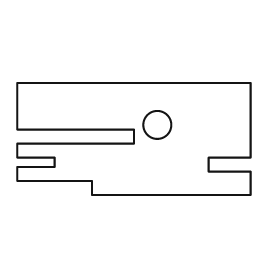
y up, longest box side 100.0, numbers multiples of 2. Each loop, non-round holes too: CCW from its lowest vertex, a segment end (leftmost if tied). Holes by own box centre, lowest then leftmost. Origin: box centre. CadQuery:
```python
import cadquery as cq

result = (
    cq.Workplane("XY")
    .moveTo(-18.0, -24.0)
    .lineTo(50.0, -24.0)
    .lineTo(50.0, -14.0)
    .lineTo(32.0, -14.0)
    .lineTo(32.0, -8.0)
    .lineTo(50.0, -8.0)
    .lineTo(50.0, 24.0)
    .lineTo(-50.0, 24.0)
    .lineTo(-50.0, 4.0)
    .lineTo(0.0, 4.0)
    .lineTo(0.0, -2.0)
    .lineTo(-50.0, -2.0)
    .lineTo(-50.0, -8.0)
    .lineTo(-34.0, -8.0)
    .lineTo(-34.0, -12.0)
    .lineTo(-50.0, -12.0)
    .lineTo(-50.0, -18.0)
    .lineTo(-18.0, -18.0)
    .close()
    .moveTo(10.0, 6.0)
    .circle(6.0)
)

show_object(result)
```